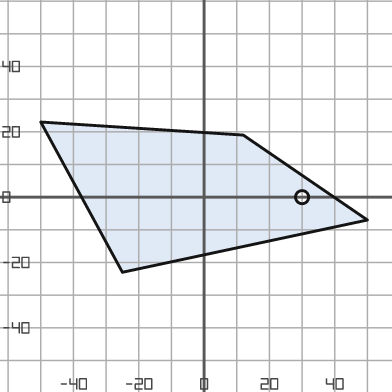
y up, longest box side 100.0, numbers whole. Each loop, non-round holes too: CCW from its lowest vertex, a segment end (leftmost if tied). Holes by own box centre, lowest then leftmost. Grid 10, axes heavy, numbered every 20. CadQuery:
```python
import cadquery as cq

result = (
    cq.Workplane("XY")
    .moveTo(-25.0, -23.0)
    .lineTo(50.0, -7.0)
    .lineTo(12.0, 19.0)
    .lineTo(-50.0, 23.0)
    .close()
    .moveTo(30.0, 0.0)
    .circle(2.0)
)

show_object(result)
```